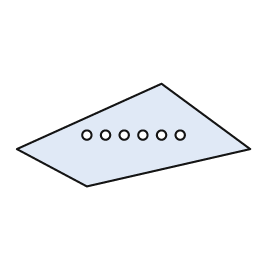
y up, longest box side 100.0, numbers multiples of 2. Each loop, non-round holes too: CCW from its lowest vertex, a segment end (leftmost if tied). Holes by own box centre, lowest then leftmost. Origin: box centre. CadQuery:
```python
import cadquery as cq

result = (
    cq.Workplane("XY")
    .moveTo(-20.0, -22.0)
    .lineTo(50.0, -6.0)
    .lineTo(12.0, 22.0)
    .lineTo(-50.0, -6.0)
    .close()
    .moveTo(-20.0, 0.0)
    .circle(2.0)
    .moveTo(-12.0, 0.0)
    .circle(2.0)
    .moveTo(-4.0, 0.0)
    .circle(2.0)
    .moveTo(4.0, 0.0)
    .circle(2.0)
    .moveTo(12.0, 0.0)
    .circle(2.0)
    .moveTo(20.0, 0.0)
    .circle(2.0)
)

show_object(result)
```